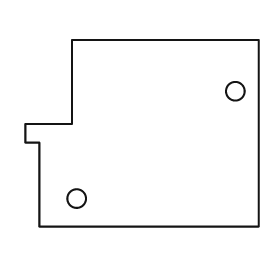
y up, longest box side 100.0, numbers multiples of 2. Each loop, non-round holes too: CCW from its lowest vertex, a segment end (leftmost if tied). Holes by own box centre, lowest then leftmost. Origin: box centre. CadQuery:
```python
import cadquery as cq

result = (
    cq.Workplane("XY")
    .moveTo(-44.0, -40.0)
    .lineTo(50.0, -40.0)
    .lineTo(50.0, 40.0)
    .lineTo(-30.0, 40.0)
    .lineTo(-30.0, 4.0)
    .lineTo(-50.0, 4.0)
    .lineTo(-50.0, -4.0)
    .lineTo(-44.0, -4.0)
    .close()
    .moveTo(-28.0, -28.0)
    .circle(4.0)
    .moveTo(40.0, 18.0)
    .circle(4.0)
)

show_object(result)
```